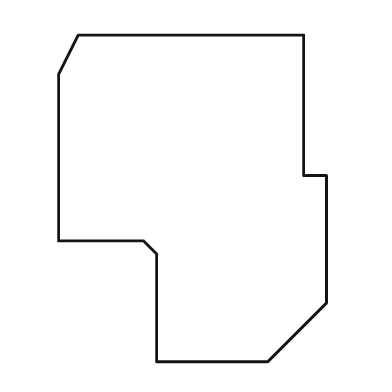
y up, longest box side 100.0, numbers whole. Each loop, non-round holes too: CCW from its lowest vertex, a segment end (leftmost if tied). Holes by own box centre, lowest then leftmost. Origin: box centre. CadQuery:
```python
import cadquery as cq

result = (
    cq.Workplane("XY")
    .moveTo(-11.0, -50.0)
    .lineTo(23.0, -50.0)
    .lineTo(41.0, -32.0)
    .lineTo(41.0, 7.0)
    .lineTo(34.0, 7.0)
    .lineTo(34.0, 50.0)
    .lineTo(-35.0, 50.0)
    .lineTo(-41.0, 38.0)
    .lineTo(-41.0, -13.0)
    .lineTo(-15.0, -13.0)
    .lineTo(-11.0, -17.0)
    .close()
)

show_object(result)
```